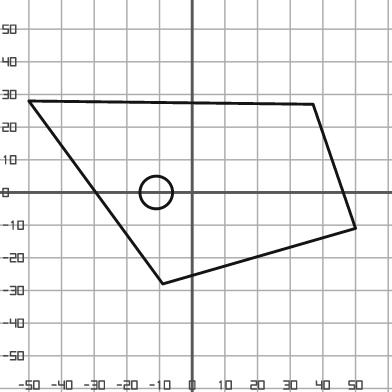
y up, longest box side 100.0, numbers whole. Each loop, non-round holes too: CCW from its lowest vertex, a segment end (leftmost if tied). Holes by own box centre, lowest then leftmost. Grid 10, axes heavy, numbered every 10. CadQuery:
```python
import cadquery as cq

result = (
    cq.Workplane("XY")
    .moveTo(-9.0, -28.0)
    .lineTo(50.0, -11.0)
    .lineTo(37.0, 27.0)
    .lineTo(-50.0, 28.0)
    .close()
    .moveTo(-11.0, 0.0)
    .circle(5.0)
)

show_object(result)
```